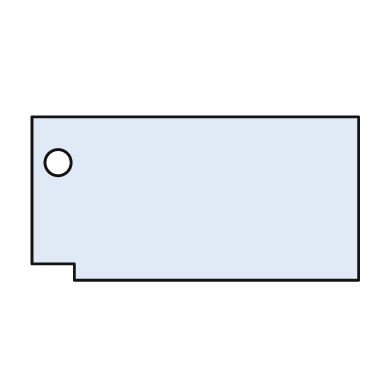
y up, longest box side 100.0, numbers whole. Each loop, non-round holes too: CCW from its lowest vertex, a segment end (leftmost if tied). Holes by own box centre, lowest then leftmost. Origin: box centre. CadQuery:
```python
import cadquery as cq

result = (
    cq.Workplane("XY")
    .moveTo(-37.0, -25.0)
    .lineTo(50.0, -25.0)
    .lineTo(50.0, 25.0)
    .lineTo(-50.0, 25.0)
    .lineTo(-50.0, -20.0)
    .lineTo(-37.0, -20.0)
    .close()
    .moveTo(-42.0, 11.0)
    .circle(4.0)
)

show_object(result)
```